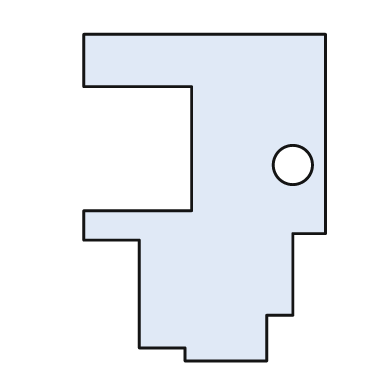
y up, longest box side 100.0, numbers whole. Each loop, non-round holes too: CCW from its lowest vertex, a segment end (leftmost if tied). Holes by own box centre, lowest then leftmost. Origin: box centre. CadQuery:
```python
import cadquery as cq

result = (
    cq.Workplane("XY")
    .moveTo(-6.0, -50.0)
    .lineTo(19.0, -50.0)
    .lineTo(19.0, -36.0)
    .lineTo(27.0, -36.0)
    .lineTo(27.0, -11.0)
    .lineTo(37.0, -11.0)
    .lineTo(37.0, 50.0)
    .lineTo(-37.0, 50.0)
    .lineTo(-37.0, 34.0)
    .lineTo(-4.0, 34.0)
    .lineTo(-4.0, -4.0)
    .lineTo(-37.0, -4.0)
    .lineTo(-37.0, -13.0)
    .lineTo(-20.0, -13.0)
    .lineTo(-20.0, -46.0)
    .lineTo(-6.0, -46.0)
    .close()
    .moveTo(27.0, 10.0)
    .circle(6.0)
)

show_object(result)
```